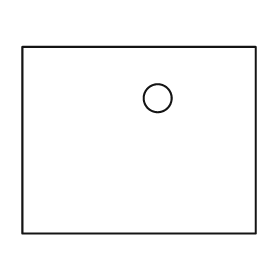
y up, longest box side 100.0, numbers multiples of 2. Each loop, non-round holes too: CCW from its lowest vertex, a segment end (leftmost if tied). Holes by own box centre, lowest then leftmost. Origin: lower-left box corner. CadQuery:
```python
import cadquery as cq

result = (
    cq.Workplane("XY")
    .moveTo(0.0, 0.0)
    .lineTo(100.0, 0.0)
    .lineTo(100.0, 80.0)
    .lineTo(0.0, 80.0)
    .close()
    .moveTo(58.0, 58.0)
    .circle(6.0)
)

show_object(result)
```